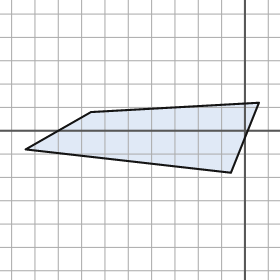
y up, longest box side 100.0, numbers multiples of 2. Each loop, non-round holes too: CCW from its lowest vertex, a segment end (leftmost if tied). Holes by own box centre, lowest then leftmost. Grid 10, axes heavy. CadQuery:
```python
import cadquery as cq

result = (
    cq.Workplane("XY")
    .moveTo(-6.0, -18.0)
    .lineTo(6.0, 12.0)
    .lineTo(-66.0, 8.0)
    .lineTo(-94.0, -8.0)
    .close()
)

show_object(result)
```